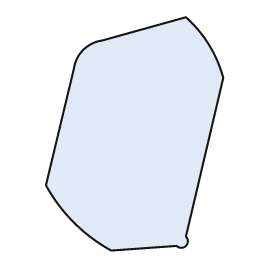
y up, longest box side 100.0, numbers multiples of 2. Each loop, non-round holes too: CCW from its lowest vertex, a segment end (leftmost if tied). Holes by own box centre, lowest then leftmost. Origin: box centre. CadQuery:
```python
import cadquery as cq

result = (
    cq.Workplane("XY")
    .moveTo(-10.0, -50.0)
    .lineTo(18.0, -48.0)
    .threePointArc((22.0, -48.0), (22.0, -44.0))
    .lineTo(38.0, 24.0)
    .threePointArc((32.0, 38.0), (22.0, 50.0))
    .lineTo(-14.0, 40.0)
    .threePointArc((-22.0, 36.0), (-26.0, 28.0))
    .lineTo(-38.0, -22.0)
    .threePointArc((-26.0, -38.0), (-10.0, -50.0))
    .close()
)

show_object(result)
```